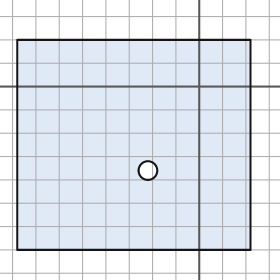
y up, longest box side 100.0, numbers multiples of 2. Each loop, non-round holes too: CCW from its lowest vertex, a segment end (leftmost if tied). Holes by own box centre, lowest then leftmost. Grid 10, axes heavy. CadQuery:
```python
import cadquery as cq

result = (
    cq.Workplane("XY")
    .moveTo(-78.0, -70.0)
    .lineTo(22.0, -70.0)
    .lineTo(22.0, 20.0)
    .lineTo(-78.0, 20.0)
    .close()
    .moveTo(-22.0, -36.0)
    .circle(4.0)
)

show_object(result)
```